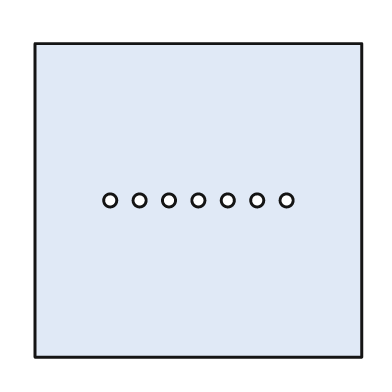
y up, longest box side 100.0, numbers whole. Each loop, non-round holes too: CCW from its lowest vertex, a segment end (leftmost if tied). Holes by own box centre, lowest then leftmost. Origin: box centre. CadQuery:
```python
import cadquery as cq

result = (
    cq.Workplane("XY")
    .moveTo(-50.0, -48.0)
    .lineTo(50.0, -48.0)
    .lineTo(50.0, 48.0)
    .lineTo(-50.0, 48.0)
    .close()
    .moveTo(-27.0, 0.0)
    .circle(2.0)
    .moveTo(-18.0, 0.0)
    .circle(2.0)
    .moveTo(-9.0, 0.0)
    .circle(2.0)
    .moveTo(0.0, 0.0)
    .circle(2.0)
    .moveTo(9.0, 0.0)
    .circle(2.0)
    .moveTo(18.0, 0.0)
    .circle(2.0)
    .moveTo(27.0, 0.0)
    .circle(2.0)
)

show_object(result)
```